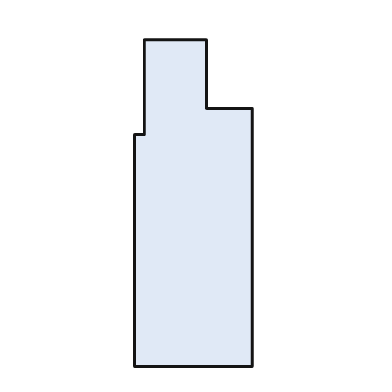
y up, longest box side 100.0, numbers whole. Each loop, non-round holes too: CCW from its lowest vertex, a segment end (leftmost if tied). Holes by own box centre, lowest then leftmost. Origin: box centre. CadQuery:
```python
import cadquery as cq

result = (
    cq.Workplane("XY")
    .moveTo(-18.0, -50.0)
    .lineTo(18.0, -50.0)
    .lineTo(18.0, 29.0)
    .lineTo(4.0, 29.0)
    .lineTo(4.0, 50.0)
    .lineTo(-15.0, 50.0)
    .lineTo(-15.0, 21.0)
    .lineTo(-18.0, 21.0)
    .close()
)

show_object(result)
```